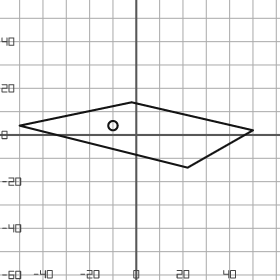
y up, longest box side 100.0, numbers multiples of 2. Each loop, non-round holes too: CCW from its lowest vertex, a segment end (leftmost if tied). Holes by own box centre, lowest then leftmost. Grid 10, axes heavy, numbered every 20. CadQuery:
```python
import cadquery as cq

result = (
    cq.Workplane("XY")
    .moveTo(22.0, -14.0)
    .lineTo(50.0, 2.0)
    .lineTo(-2.0, 14.0)
    .lineTo(-50.0, 4.0)
    .close()
    .moveTo(-10.0, 4.0)
    .circle(2.0)
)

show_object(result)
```